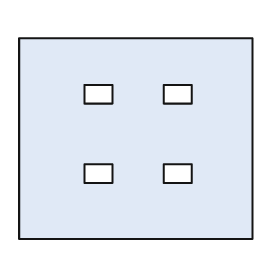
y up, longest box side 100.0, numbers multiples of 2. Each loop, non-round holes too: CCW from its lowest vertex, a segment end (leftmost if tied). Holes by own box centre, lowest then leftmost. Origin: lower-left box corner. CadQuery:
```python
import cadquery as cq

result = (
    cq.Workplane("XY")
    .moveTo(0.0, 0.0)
    .lineTo(100.0, 0.0)
    .lineTo(100.0, 86.0)
    .lineTo(0.0, 86.0)
    .close()
    .moveTo(28.0, 24.0)
    .lineTo(40.0, 24.0)
    .lineTo(40.0, 32.0)
    .lineTo(28.0, 32.0)
    .close()
    .moveTo(62.0, 24.0)
    .lineTo(74.0, 24.0)
    .lineTo(74.0, 32.0)
    .lineTo(62.0, 32.0)
    .close()
    .moveTo(28.0, 58.0)
    .lineTo(40.0, 58.0)
    .lineTo(40.0, 66.0)
    .lineTo(28.0, 66.0)
    .close()
    .moveTo(62.0, 58.0)
    .lineTo(74.0, 58.0)
    .lineTo(74.0, 66.0)
    .lineTo(62.0, 66.0)
    .close()
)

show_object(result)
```